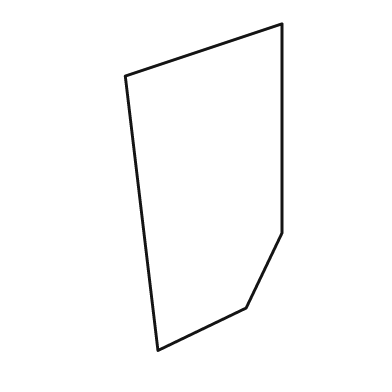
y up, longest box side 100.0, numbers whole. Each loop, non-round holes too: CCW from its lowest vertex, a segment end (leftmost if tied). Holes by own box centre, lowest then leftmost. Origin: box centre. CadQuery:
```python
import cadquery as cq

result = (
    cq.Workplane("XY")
    .moveTo(-14.0, -50.0)
    .lineTo(13.0, -37.0)
    .lineTo(24.0, -14.0)
    .lineTo(24.0, 50.0)
    .lineTo(-24.0, 34.0)
    .close()
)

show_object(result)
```